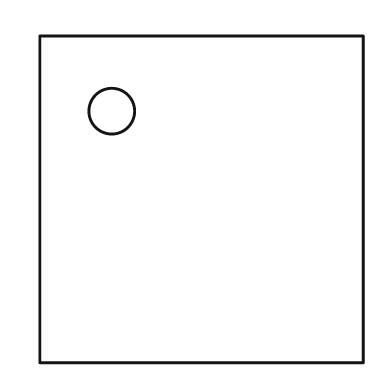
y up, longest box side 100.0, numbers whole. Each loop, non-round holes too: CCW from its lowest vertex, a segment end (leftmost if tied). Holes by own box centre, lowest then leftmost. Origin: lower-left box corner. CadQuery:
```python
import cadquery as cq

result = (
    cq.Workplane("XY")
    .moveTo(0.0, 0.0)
    .lineTo(99.0, 0.0)
    .lineTo(99.0, 100.0)
    .lineTo(0.0, 100.0)
    .close()
    .moveTo(22.0, 77.0)
    .circle(7.0)
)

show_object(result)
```